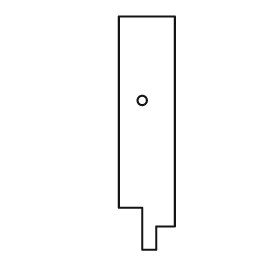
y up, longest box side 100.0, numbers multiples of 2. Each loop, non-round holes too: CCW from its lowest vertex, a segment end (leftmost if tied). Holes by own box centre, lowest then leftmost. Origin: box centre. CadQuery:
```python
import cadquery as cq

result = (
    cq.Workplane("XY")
    .moveTo(-2.0, -50.0)
    .lineTo(4.0, -50.0)
    .lineTo(4.0, -40.0)
    .lineTo(12.0, -40.0)
    .lineTo(12.0, 50.0)
    .lineTo(-12.0, 50.0)
    .lineTo(-12.0, -32.0)
    .lineTo(-2.0, -32.0)
    .close()
    .moveTo(-2.0, 14.0)
    .circle(2.0)
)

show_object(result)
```